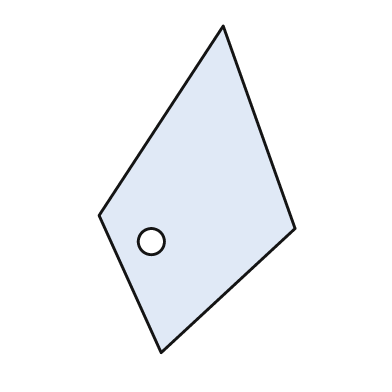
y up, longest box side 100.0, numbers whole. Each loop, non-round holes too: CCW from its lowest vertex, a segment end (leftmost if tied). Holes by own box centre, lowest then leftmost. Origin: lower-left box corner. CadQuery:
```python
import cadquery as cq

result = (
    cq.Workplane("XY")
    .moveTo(19.0, 0.0)
    .lineTo(60.0, 38.0)
    .lineTo(38.0, 100.0)
    .lineTo(0.0, 42.0)
    .close()
    .moveTo(16.0, 34.0)
    .circle(4.0)
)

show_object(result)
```